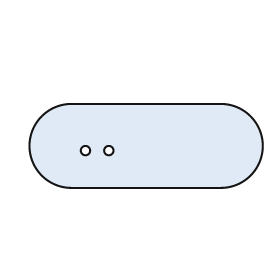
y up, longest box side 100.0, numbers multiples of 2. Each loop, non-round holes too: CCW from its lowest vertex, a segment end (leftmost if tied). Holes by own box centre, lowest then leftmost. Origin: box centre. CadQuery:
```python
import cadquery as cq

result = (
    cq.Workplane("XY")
    .moveTo(-32.0, -18.0)
    .lineTo(32.0, -18.0)
    .threePointArc((50.0, 0.0), (32.0, 18.0))
    .lineTo(-32.0, 18.0)
    .threePointArc((-50.0, 0.0), (-32.0, -18.0))
    .close()
    .moveTo(-26.0, -2.0)
    .circle(2.0)
    .moveTo(-16.0, -2.0)
    .circle(2.0)
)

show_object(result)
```